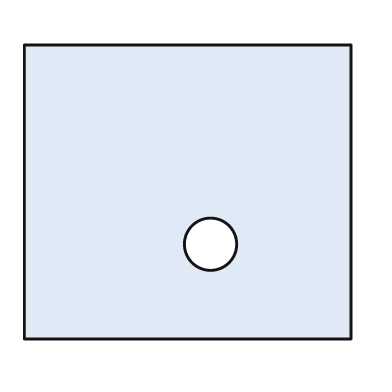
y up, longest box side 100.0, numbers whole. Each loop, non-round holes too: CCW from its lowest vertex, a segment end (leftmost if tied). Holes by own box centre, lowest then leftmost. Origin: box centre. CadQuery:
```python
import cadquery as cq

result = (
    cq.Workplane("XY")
    .moveTo(-50.0, -45.0)
    .lineTo(50.0, -45.0)
    .lineTo(50.0, 45.0)
    .lineTo(-50.0, 45.0)
    .close()
    .moveTo(7.0, -16.0)
    .circle(8.0)
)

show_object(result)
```